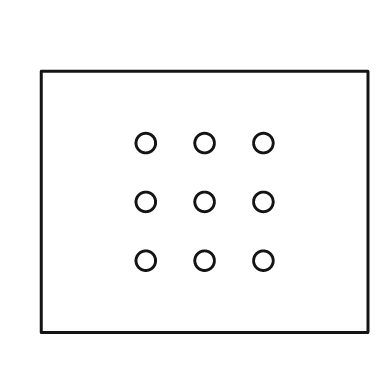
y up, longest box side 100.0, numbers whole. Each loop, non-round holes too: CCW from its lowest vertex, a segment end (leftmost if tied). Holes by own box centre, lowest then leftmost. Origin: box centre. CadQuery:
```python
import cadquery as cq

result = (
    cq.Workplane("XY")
    .moveTo(-50.0, -40.0)
    .lineTo(50.0, -40.0)
    .lineTo(50.0, 40.0)
    .lineTo(-50.0, 40.0)
    .close()
    .moveTo(-18.0, -18.0)
    .circle(3.0)
    .moveTo(0.0, -18.0)
    .circle(3.0)
    .moveTo(18.0, -18.0)
    .circle(3.0)
    .moveTo(-18.0, 0.0)
    .circle(3.0)
    .moveTo(0.0, 0.0)
    .circle(3.0)
    .moveTo(18.0, 0.0)
    .circle(3.0)
    .moveTo(-18.0, 18.0)
    .circle(3.0)
    .moveTo(0.0, 18.0)
    .circle(3.0)
    .moveTo(18.0, 18.0)
    .circle(3.0)
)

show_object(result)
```